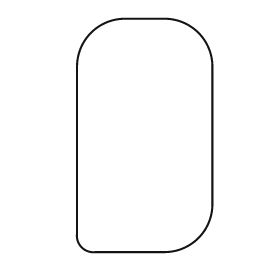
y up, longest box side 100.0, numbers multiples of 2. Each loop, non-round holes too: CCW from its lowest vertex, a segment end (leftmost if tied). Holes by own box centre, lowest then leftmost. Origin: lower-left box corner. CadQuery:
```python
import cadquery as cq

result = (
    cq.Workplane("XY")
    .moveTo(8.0, 0.0)
    .lineTo(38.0, 0.0)
    .threePointArc((52.0, 6.0), (58.0, 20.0))
    .lineTo(58.0, 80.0)
    .threePointArc((52.0, 94.0), (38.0, 100.0))
    .lineTo(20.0, 100.0)
    .threePointArc((6.0, 94.0), (0.0, 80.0))
    .lineTo(0.0, 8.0)
    .threePointArc((2.0, 2.0), (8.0, 0.0))
    .close()
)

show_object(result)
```